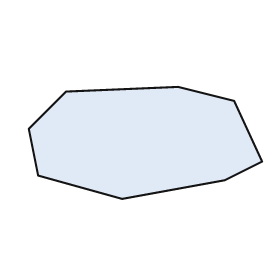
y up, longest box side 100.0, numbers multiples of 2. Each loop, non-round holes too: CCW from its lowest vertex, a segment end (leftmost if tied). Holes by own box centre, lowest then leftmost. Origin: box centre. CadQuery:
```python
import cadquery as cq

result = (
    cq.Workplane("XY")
    .moveTo(-10.0, -24.0)
    .lineTo(34.0, -16.0)
    .lineTo(50.0, -8.0)
    .lineTo(38.0, 18.0)
    .lineTo(14.0, 24.0)
    .lineTo(-34.0, 22.0)
    .lineTo(-50.0, 6.0)
    .lineTo(-46.0, -14.0)
    .close()
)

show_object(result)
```